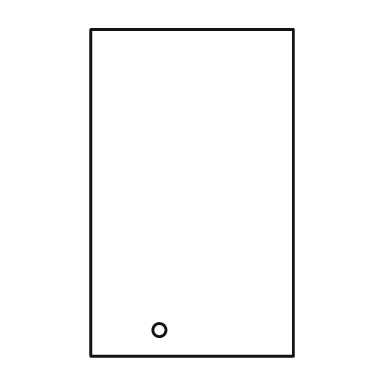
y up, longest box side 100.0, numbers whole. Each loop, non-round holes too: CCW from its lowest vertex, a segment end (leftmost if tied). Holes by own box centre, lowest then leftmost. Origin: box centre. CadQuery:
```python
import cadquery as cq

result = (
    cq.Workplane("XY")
    .moveTo(-31.0, -50.0)
    .lineTo(31.0, -50.0)
    .lineTo(31.0, 50.0)
    .lineTo(-31.0, 50.0)
    .close()
    .moveTo(-10.0, -42.0)
    .circle(2.0)
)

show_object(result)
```